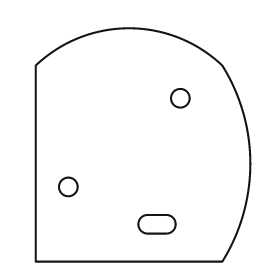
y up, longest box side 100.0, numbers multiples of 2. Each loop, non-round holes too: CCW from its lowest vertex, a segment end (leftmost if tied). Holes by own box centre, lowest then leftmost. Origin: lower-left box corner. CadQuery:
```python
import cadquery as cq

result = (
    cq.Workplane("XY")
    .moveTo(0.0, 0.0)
    .lineTo(80.0, 0.0)
    .threePointArc((92.0, 42.0), (80.0, 84.0))
    .threePointArc((40.0, 100.0), (0.0, 84.0))
    .close()
    .moveTo(48.0, 12.0)
    .lineTo(56.0, 12.0)
    .threePointArc((60.0, 16.0), (56.0, 20.0))
    .lineTo(48.0, 20.0)
    .threePointArc((44.0, 16.0), (48.0, 12.0))
    .close()
    .moveTo(14.0, 32.0)
    .circle(4.0)
    .moveTo(62.0, 70.0)
    .circle(4.0)
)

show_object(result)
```